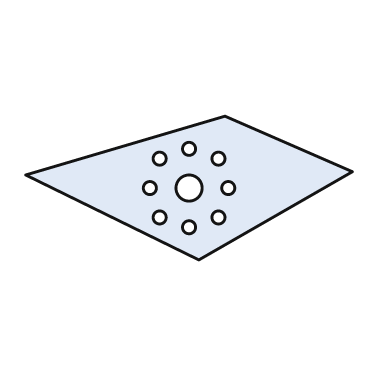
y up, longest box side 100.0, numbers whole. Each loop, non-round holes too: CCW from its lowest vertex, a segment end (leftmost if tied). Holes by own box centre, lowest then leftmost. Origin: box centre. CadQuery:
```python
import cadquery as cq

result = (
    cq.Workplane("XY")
    .moveTo(3.0, -22.0)
    .lineTo(50.0, 5.0)
    .lineTo(11.0, 22.0)
    .lineTo(-50.0, 4.0)
    .close()
    .moveTo(0.0, -12.0)
    .circle(2.0)
    .moveTo(-9.0, -9.0)
    .circle(2.0)
    .moveTo(9.0, -9.0)
    .circle(2.0)
    .moveTo(-12.0, 0.0)
    .circle(2.0)
    .moveTo(0.0, 0.0)
    .circle(4.0)
    .moveTo(12.0, 0.0)
    .circle(2.0)
    .moveTo(-9.0, 9.0)
    .circle(2.0)
    .moveTo(9.0, 9.0)
    .circle(2.0)
    .moveTo(0.0, 12.0)
    .circle(2.0)
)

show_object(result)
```